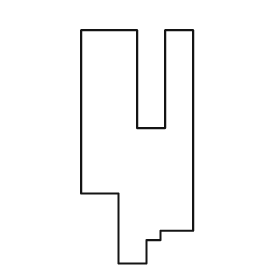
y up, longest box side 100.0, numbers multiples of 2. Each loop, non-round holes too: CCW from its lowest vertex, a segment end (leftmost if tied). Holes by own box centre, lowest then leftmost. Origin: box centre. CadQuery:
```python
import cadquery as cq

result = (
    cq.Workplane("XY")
    .moveTo(-8.0, -50.0)
    .lineTo(4.0, -50.0)
    .lineTo(4.0, -40.0)
    .lineTo(10.0, -40.0)
    .lineTo(10.0, -36.0)
    .lineTo(24.0, -36.0)
    .lineTo(24.0, 50.0)
    .lineTo(12.0, 50.0)
    .lineTo(12.0, 8.0)
    .lineTo(0.0, 8.0)
    .lineTo(0.0, 50.0)
    .lineTo(-24.0, 50.0)
    .lineTo(-24.0, -20.0)
    .lineTo(-8.0, -20.0)
    .close()
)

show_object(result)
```